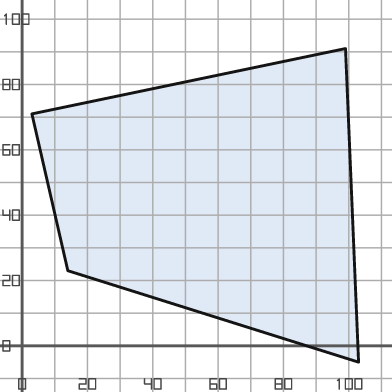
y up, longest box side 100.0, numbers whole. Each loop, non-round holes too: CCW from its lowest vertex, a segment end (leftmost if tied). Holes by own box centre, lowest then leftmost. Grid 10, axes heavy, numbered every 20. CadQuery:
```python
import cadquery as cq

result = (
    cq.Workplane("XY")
    .moveTo(103.0, -5.0)
    .lineTo(99.0, 91.0)
    .lineTo(3.0, 71.0)
    .lineTo(14.0, 23.0)
    .close()
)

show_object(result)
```